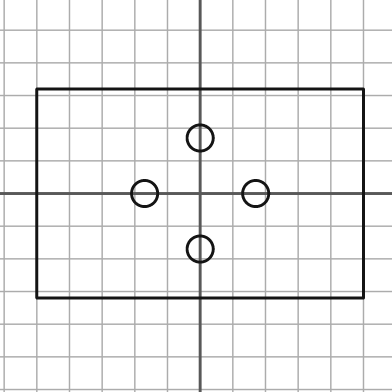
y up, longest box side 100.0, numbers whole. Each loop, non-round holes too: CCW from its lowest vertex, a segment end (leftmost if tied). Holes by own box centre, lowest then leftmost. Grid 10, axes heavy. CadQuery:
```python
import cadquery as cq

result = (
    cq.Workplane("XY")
    .moveTo(-50.0, -32.0)
    .lineTo(50.0, -32.0)
    .lineTo(50.0, 32.0)
    .lineTo(-50.0, 32.0)
    .close()
    .moveTo(0.0, -17.0)
    .circle(4.0)
    .moveTo(-17.0, 0.0)
    .circle(4.0)
    .moveTo(17.0, 0.0)
    .circle(4.0)
    .moveTo(0.0, 17.0)
    .circle(4.0)
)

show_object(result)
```